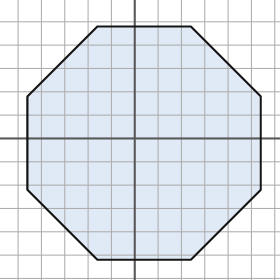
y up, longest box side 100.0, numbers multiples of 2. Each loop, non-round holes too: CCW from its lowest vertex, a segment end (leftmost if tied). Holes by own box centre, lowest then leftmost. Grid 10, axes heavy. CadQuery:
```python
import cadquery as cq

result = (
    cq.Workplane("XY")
    .moveTo(-16.0, -52.0)
    .lineTo(24.0, -52.0)
    .lineTo(54.0, -22.0)
    .lineTo(54.0, 18.0)
    .lineTo(24.0, 48.0)
    .lineTo(-16.0, 48.0)
    .lineTo(-46.0, 18.0)
    .lineTo(-46.0, -22.0)
    .close()
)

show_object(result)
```